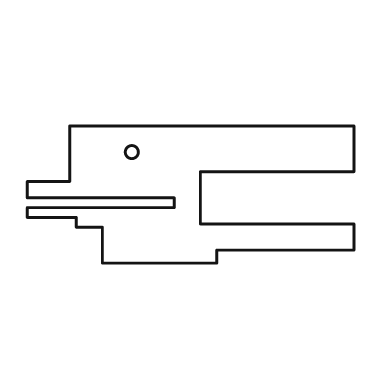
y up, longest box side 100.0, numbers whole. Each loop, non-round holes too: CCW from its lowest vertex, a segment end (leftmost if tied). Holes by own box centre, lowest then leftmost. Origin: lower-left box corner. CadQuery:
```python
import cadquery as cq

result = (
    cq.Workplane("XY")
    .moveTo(23.0, 0.0)
    .lineTo(58.0, 0.0)
    .lineTo(58.0, 4.0)
    .lineTo(100.0, 4.0)
    .lineTo(100.0, 12.0)
    .lineTo(53.0, 12.0)
    .lineTo(53.0, 28.0)
    .lineTo(100.0, 28.0)
    .lineTo(100.0, 42.0)
    .lineTo(13.0, 42.0)
    .lineTo(13.0, 25.0)
    .lineTo(0.0, 25.0)
    .lineTo(0.0, 20.0)
    .lineTo(45.0, 20.0)
    .lineTo(45.0, 17.0)
    .lineTo(0.0, 17.0)
    .lineTo(0.0, 14.0)
    .lineTo(15.0, 14.0)
    .lineTo(15.0, 11.0)
    .lineTo(23.0, 11.0)
    .close()
    .moveTo(32.0, 34.0)
    .circle(2.0)
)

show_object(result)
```